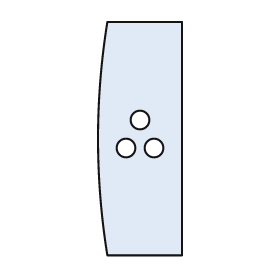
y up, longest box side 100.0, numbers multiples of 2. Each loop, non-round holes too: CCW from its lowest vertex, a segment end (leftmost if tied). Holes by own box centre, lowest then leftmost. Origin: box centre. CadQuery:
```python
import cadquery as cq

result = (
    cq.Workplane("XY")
    .moveTo(-14.0, -50.0)
    .lineTo(18.0, -50.0)
    .lineTo(18.0, 50.0)
    .lineTo(-14.0, 50.0)
    .threePointArc((-18.0, 0.0), (-14.0, -50.0))
    .close()
    .moveTo(-6.0, -4.0)
    .circle(4.0)
    .moveTo(6.0, -4.0)
    .circle(4.0)
    .moveTo(0.0, 8.0)
    .circle(4.0)
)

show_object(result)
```